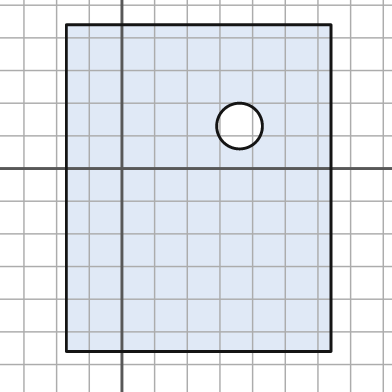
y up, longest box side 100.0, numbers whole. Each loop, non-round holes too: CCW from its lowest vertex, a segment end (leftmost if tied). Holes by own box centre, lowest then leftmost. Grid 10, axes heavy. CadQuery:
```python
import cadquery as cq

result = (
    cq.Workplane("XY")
    .moveTo(-17.0, -56.0)
    .lineTo(64.0, -56.0)
    .lineTo(64.0, 44.0)
    .lineTo(-17.0, 44.0)
    .close()
    .moveTo(36.0, 13.0)
    .circle(7.0)
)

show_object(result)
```